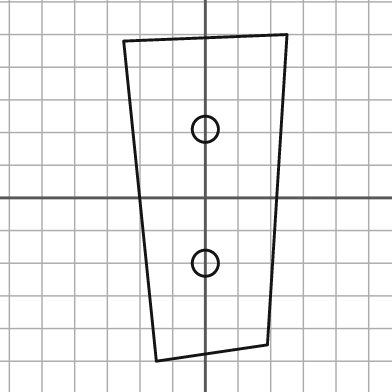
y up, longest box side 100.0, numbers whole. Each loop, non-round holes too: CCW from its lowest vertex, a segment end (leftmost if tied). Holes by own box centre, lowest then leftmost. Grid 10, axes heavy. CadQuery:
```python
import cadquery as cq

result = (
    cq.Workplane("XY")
    .moveTo(-15.0, -50.0)
    .lineTo(19.0, -45.0)
    .lineTo(25.0, 50.0)
    .lineTo(-25.0, 48.0)
    .close()
    .moveTo(0.0, -20.0)
    .circle(4.0)
    .moveTo(0.0, 21.0)
    .circle(4.0)
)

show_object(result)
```